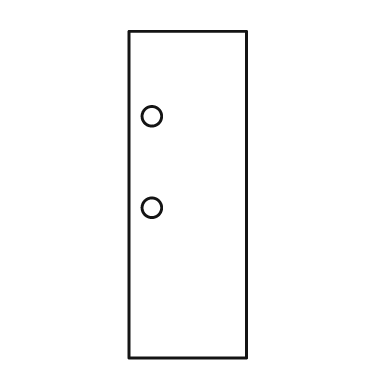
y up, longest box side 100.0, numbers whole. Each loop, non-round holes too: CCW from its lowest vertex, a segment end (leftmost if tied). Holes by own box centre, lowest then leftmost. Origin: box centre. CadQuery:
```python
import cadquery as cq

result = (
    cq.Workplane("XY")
    .moveTo(-18.0, -50.0)
    .lineTo(18.0, -50.0)
    .lineTo(18.0, 50.0)
    .lineTo(-18.0, 50.0)
    .close()
    .moveTo(-11.0, -4.0)
    .circle(3.0)
    .moveTo(-11.0, 24.0)
    .circle(3.0)
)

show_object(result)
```